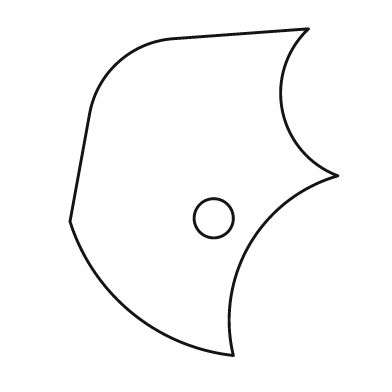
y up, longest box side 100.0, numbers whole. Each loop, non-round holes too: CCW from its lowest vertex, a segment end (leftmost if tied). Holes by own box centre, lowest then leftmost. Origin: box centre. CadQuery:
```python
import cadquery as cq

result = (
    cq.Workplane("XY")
    .moveTo(9.0, -50.0)
    .threePointArc((14.0, -16.0), (41.0, 5.0))
    .threePointArc((24.0, 25.0), (32.0, 50.0))
    .lineTo(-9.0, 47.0)
    .threePointArc((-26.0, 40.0), (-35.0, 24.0))
    .lineTo(-41.0, -9.0)
    .threePointArc((-22.0, -37.0), (9.0, -50.0))
    .close()
    .moveTo(3.0, -8.0)
    .circle(6.0)
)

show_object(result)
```